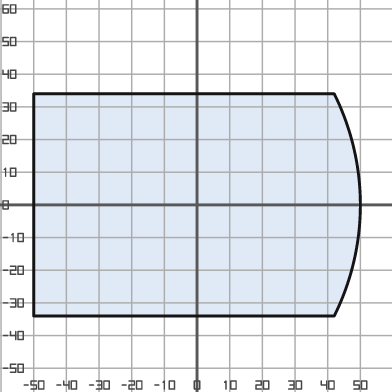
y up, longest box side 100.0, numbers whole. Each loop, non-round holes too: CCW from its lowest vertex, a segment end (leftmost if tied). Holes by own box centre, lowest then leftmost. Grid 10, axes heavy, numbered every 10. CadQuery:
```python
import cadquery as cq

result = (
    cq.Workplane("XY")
    .moveTo(-50.0, -34.0)
    .lineTo(42.0, -34.0)
    .threePointArc((50.0, 0.0), (42.0, 34.0))
    .lineTo(-50.0, 34.0)
    .close()
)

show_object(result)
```